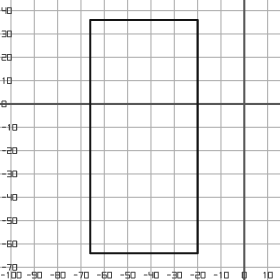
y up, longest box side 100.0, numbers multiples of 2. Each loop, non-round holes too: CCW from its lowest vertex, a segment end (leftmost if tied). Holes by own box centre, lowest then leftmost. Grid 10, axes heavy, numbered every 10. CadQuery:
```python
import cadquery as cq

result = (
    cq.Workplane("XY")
    .moveTo(-66.0, -64.0)
    .lineTo(-20.0, -64.0)
    .lineTo(-20.0, 36.0)
    .lineTo(-66.0, 36.0)
    .close()
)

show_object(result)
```